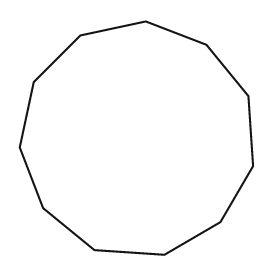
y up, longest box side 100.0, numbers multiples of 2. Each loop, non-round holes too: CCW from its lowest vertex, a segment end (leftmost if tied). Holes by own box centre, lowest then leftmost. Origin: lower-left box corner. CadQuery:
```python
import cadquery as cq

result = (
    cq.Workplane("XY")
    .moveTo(62.0, 0.0)
    .lineTo(86.0, 14.0)
    .lineTo(100.0, 38.0)
    .lineTo(98.0, 68.0)
    .lineTo(80.0, 90.0)
    .lineTo(54.0, 100.0)
    .lineTo(26.0, 94.0)
    .lineTo(6.0, 74.0)
    .lineTo(0.0, 46.0)
    .lineTo(10.0, 20.0)
    .lineTo(32.0, 2.0)
    .close()
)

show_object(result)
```